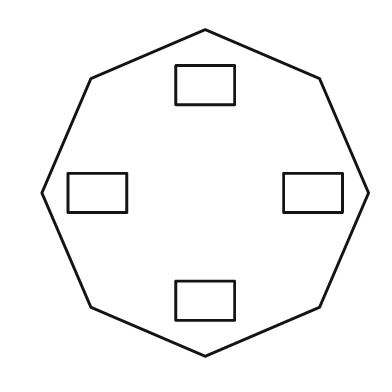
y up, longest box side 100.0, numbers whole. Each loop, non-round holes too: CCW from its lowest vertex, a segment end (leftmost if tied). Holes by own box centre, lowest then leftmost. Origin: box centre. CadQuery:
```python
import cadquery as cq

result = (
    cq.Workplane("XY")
    .moveTo(0.0, -50.0)
    .lineTo(35.0, -35.0)
    .lineTo(50.0, 0.0)
    .lineTo(35.0, 35.0)
    .lineTo(0.0, 50.0)
    .lineTo(-35.0, 35.0)
    .lineTo(-50.0, 0.0)
    .lineTo(-35.0, -35.0)
    .close()
    .moveTo(-9.0, -39.0)
    .lineTo(9.0, -39.0)
    .lineTo(9.0, -27.0)
    .lineTo(-9.0, -27.0)
    .close()
    .moveTo(-42.0, -6.0)
    .lineTo(-24.0, -6.0)
    .lineTo(-24.0, 6.0)
    .lineTo(-42.0, 6.0)
    .close()
    .moveTo(24.0, -6.0)
    .lineTo(42.0, -6.0)
    .lineTo(42.0, 6.0)
    .lineTo(24.0, 6.0)
    .close()
    .moveTo(-9.0, 27.0)
    .lineTo(9.0, 27.0)
    .lineTo(9.0, 39.0)
    .lineTo(-9.0, 39.0)
    .close()
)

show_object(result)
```